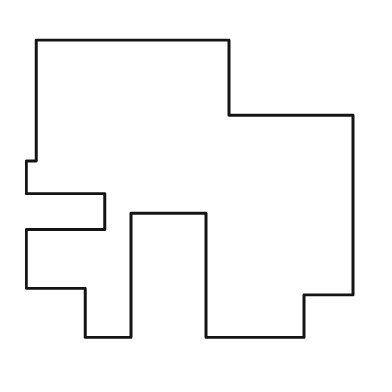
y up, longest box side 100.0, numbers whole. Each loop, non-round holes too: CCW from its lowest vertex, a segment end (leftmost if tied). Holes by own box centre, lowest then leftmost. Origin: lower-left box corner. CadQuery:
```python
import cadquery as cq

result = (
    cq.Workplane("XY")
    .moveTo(18.0, 0.0)
    .lineTo(32.0, 0.0)
    .lineTo(32.0, 38.0)
    .lineTo(55.0, 38.0)
    .lineTo(55.0, 0.0)
    .lineTo(85.0, 0.0)
    .lineTo(85.0, 13.0)
    .lineTo(100.0, 13.0)
    .lineTo(100.0, 68.0)
    .lineTo(62.0, 68.0)
    .lineTo(62.0, 91.0)
    .lineTo(3.0, 91.0)
    .lineTo(3.0, 54.0)
    .lineTo(0.0, 54.0)
    .lineTo(0.0, 44.0)
    .lineTo(24.0, 44.0)
    .lineTo(24.0, 33.0)
    .lineTo(0.0, 33.0)
    .lineTo(0.0, 15.0)
    .lineTo(18.0, 15.0)
    .close()
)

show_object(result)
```